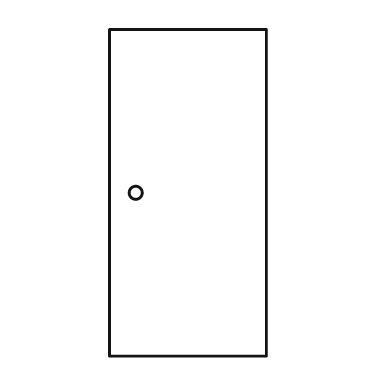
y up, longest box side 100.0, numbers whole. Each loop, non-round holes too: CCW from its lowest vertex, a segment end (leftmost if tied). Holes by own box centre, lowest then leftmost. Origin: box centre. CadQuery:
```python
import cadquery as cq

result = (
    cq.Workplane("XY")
    .moveTo(-24.0, -50.0)
    .lineTo(24.0, -50.0)
    .lineTo(24.0, 50.0)
    .lineTo(-24.0, 50.0)
    .close()
    .moveTo(-16.0, 0.0)
    .circle(2.0)
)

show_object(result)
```